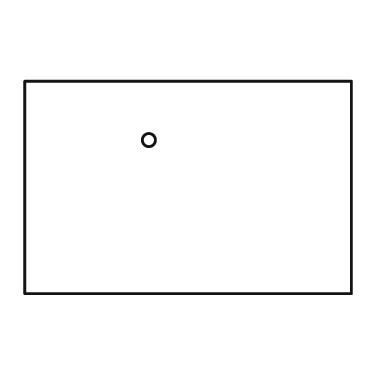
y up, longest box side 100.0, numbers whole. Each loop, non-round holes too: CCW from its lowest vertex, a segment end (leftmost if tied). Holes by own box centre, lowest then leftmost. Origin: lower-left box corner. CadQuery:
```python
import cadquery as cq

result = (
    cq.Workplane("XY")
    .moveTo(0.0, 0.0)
    .lineTo(100.0, 0.0)
    .lineTo(100.0, 65.0)
    .lineTo(0.0, 65.0)
    .close()
    .moveTo(38.0, 47.0)
    .circle(2.0)
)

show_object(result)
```